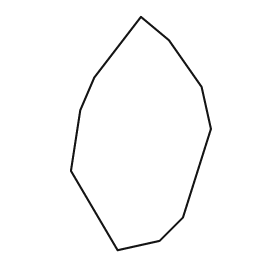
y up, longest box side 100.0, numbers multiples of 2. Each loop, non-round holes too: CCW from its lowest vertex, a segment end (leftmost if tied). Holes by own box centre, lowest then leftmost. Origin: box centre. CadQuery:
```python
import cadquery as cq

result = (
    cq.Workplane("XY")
    .moveTo(-10.0, -50.0)
    .lineTo(8.0, -46.0)
    .lineTo(18.0, -36.0)
    .lineTo(30.0, 2.0)
    .lineTo(26.0, 20.0)
    .lineTo(12.0, 40.0)
    .lineTo(0.0, 50.0)
    .lineTo(-20.0, 24.0)
    .lineTo(-26.0, 10.0)
    .lineTo(-30.0, -16.0)
    .close()
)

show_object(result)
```